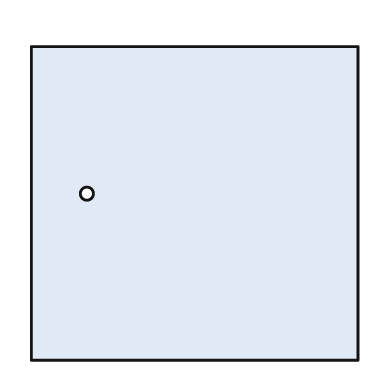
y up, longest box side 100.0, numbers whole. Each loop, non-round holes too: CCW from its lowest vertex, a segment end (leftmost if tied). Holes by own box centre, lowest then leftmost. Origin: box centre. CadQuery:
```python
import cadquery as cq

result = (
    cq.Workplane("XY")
    .moveTo(-50.0, -48.0)
    .lineTo(50.0, -48.0)
    .lineTo(50.0, 48.0)
    .lineTo(-50.0, 48.0)
    .close()
    .moveTo(-33.0, 3.0)
    .circle(2.0)
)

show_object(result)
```